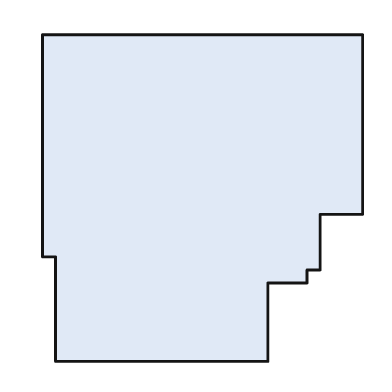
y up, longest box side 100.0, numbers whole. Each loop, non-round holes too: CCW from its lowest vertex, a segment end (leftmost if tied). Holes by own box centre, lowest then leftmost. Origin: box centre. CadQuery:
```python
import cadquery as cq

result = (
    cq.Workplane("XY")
    .moveTo(-45.0, -50.0)
    .lineTo(20.0, -50.0)
    .lineTo(20.0, -26.0)
    .lineTo(32.0, -26.0)
    .lineTo(32.0, -22.0)
    .lineTo(36.0, -22.0)
    .lineTo(36.0, -5.0)
    .lineTo(49.0, -5.0)
    .lineTo(49.0, 50.0)
    .lineTo(-49.0, 50.0)
    .lineTo(-49.0, -18.0)
    .lineTo(-45.0, -18.0)
    .close()
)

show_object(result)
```